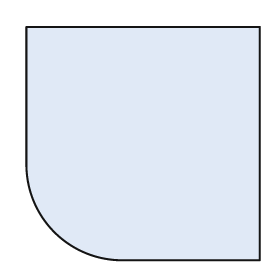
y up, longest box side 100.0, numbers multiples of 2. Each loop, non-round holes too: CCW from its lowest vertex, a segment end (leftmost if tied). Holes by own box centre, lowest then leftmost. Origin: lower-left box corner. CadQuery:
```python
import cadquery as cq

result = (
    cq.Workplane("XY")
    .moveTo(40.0, 0.0)
    .lineTo(100.0, 0.0)
    .lineTo(100.0, 100.0)
    .lineTo(0.0, 100.0)
    .lineTo(0.0, 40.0)
    .threePointArc((12.0, 12.0), (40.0, 0.0))
    .close()
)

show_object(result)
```